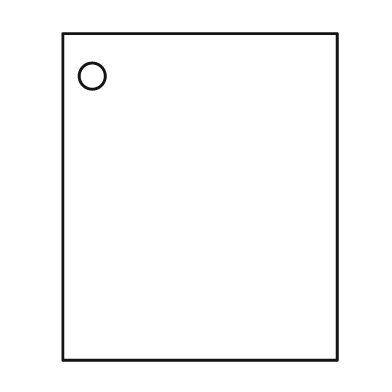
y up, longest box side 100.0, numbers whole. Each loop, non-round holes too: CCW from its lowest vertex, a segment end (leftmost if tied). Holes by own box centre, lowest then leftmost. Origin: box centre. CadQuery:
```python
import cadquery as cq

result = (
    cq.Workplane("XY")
    .moveTo(-42.0, -50.0)
    .lineTo(42.0, -50.0)
    .lineTo(42.0, 50.0)
    .lineTo(-42.0, 50.0)
    .close()
    .moveTo(-33.0, 37.0)
    .circle(4.0)
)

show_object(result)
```